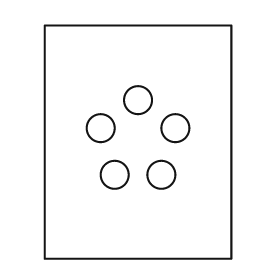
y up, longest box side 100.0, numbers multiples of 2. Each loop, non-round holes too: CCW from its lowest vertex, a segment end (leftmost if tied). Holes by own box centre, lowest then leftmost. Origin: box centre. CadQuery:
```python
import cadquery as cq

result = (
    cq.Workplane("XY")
    .moveTo(-40.0, -50.0)
    .lineTo(40.0, -50.0)
    .lineTo(40.0, 50.0)
    .lineTo(-40.0, 50.0)
    .close()
    .moveTo(-10.0, -14.0)
    .circle(6.0)
    .moveTo(10.0, -14.0)
    .circle(6.0)
    .moveTo(-16.0, 6.0)
    .circle(6.0)
    .moveTo(16.0, 6.0)
    .circle(6.0)
    .moveTo(0.0, 18.0)
    .circle(6.0)
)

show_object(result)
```